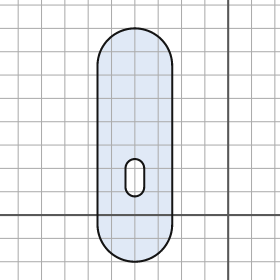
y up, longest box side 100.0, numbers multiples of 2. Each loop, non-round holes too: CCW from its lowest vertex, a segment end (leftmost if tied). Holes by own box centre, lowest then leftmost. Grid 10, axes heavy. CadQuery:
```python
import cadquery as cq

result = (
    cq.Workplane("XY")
    .moveTo(-56.0, -4.0)
    .threePointArc((-40.0, -20.0), (-24.0, -4.0))
    .lineTo(-24.0, 64.0)
    .threePointArc((-40.0, 80.0), (-56.0, 64.0))
    .close()
    .moveTo(-44.0, 12.0)
    .threePointArc((-40.0, 8.0), (-36.0, 12.0))
    .lineTo(-36.0, 20.0)
    .threePointArc((-40.0, 24.0), (-44.0, 20.0))
    .close()
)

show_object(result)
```